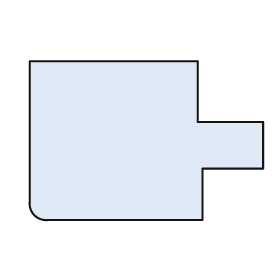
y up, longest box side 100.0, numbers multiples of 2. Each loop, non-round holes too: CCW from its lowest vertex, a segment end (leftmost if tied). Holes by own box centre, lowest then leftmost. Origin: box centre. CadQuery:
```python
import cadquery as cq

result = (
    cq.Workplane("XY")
    .moveTo(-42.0, -34.0)
    .lineTo(24.0, -34.0)
    .lineTo(24.0, -12.0)
    .lineTo(50.0, -12.0)
    .lineTo(50.0, 8.0)
    .lineTo(22.0, 8.0)
    .lineTo(22.0, 34.0)
    .lineTo(-50.0, 34.0)
    .lineTo(-50.0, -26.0)
    .threePointArc((-48.0, -32.0), (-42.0, -34.0))
    .close()
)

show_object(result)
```